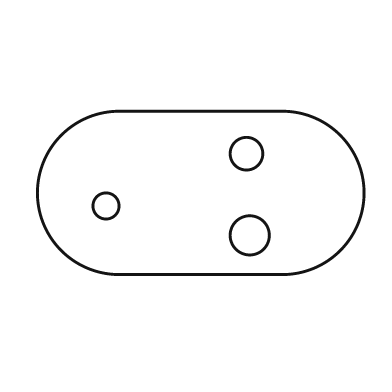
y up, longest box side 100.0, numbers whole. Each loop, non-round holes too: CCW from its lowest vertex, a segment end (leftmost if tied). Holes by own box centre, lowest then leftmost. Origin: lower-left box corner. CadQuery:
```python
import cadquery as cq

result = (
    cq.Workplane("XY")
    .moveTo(25.0, 0.0)
    .lineTo(75.0, 0.0)
    .threePointArc((100.0, 25.0), (75.0, 50.0))
    .lineTo(25.0, 50.0)
    .threePointArc((0.0, 25.0), (25.0, 0.0))
    .close()
    .moveTo(65.0, 12.0)
    .circle(6.0)
    .moveTo(21.0, 21.0)
    .circle(4.0)
    .moveTo(64.0, 37.0)
    .circle(5.0)
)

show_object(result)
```